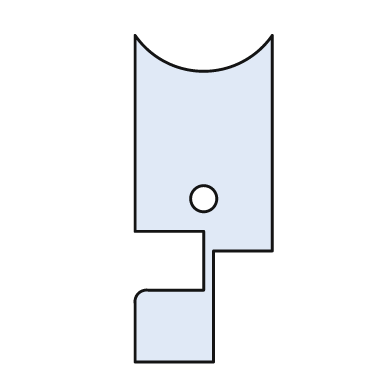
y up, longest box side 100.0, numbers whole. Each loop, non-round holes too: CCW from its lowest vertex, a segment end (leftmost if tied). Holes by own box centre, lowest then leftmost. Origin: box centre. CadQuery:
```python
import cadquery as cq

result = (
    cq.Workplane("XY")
    .moveTo(-21.0, -50.0)
    .lineTo(3.0, -50.0)
    .lineTo(3.0, -16.0)
    .lineTo(21.0, -16.0)
    .lineTo(21.0, 50.0)
    .threePointArc((0.0, 39.0), (-21.0, 50.0))
    .lineTo(-21.0, -10.0)
    .lineTo(0.0, -10.0)
    .lineTo(0.0, -28.0)
    .lineTo(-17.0, -28.0)
    .threePointArc((-20.0, -29.0), (-21.0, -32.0))
    .close()
    .moveTo(0.0, 0.0)
    .circle(4.0)
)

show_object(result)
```